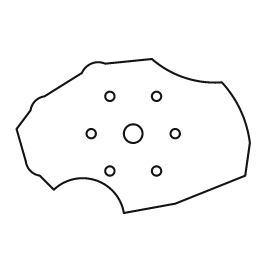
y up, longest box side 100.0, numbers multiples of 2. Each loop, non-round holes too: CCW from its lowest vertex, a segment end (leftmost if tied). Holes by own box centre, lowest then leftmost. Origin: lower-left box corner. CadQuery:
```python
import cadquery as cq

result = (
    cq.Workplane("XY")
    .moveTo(46.0, 0.0)
    .lineTo(68.0, 4.0)
    .lineTo(98.0, 16.0)
    .lineTo(100.0, 30.0)
    .threePointArc((96.0, 44.0), (88.0, 56.0))
    .threePointArc((72.0, 58.0), (58.0, 66.0))
    .lineTo(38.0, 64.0)
    .threePointArc((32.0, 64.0), (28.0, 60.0))
    .lineTo(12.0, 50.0)
    .threePointArc((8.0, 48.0), (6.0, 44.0))
    .lineTo(0.0, 36.0)
    .lineTo(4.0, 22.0)
    .threePointArc((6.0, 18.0), (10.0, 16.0))
    .lineTo(16.0, 10.0)
    .threePointArc((34.0, 14.0), (46.0, 0.0))
    .close()
    .moveTo(40.0, 18.0)
    .circle(2.0)
    .moveTo(60.0, 18.0)
    .circle(2.0)
    .moveTo(32.0, 34.0)
    .circle(2.0)
    .moveTo(50.0, 34.0)
    .circle(4.0)
    .moveTo(68.0, 34.0)
    .circle(2.0)
    .moveTo(40.0, 50.0)
    .circle(2.0)
    .moveTo(60.0, 50.0)
    .circle(2.0)
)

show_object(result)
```